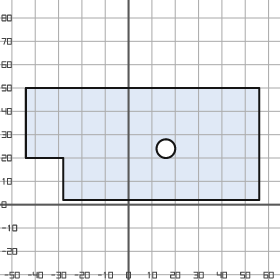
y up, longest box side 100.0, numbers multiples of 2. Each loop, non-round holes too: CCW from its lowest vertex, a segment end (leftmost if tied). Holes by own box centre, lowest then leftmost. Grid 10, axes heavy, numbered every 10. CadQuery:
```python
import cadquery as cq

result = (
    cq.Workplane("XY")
    .moveTo(-28.0, 2.0)
    .lineTo(56.0, 2.0)
    .lineTo(56.0, 50.0)
    .lineTo(-44.0, 50.0)
    .lineTo(-44.0, 20.0)
    .lineTo(-28.0, 20.0)
    .close()
    .moveTo(16.0, 24.0)
    .circle(4.0)
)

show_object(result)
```